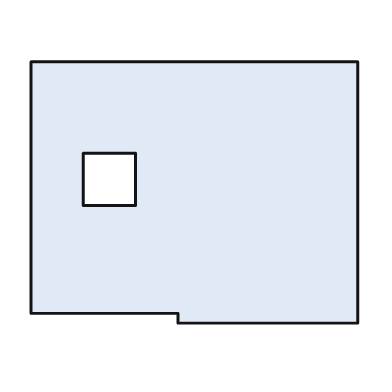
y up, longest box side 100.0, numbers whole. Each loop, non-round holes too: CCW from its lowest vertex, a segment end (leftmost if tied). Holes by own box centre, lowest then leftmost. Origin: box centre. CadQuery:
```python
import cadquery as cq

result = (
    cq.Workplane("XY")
    .moveTo(-5.0, -40.0)
    .lineTo(50.0, -40.0)
    .lineTo(50.0, 40.0)
    .lineTo(-50.0, 40.0)
    .lineTo(-50.0, -37.0)
    .lineTo(-5.0, -37.0)
    .close()
    .moveTo(-34.0, -4.0)
    .lineTo(-18.0, -4.0)
    .lineTo(-18.0, 12.0)
    .lineTo(-34.0, 12.0)
    .close()
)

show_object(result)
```